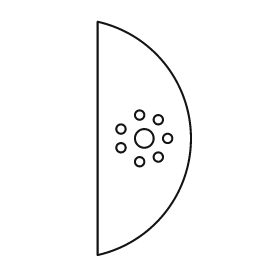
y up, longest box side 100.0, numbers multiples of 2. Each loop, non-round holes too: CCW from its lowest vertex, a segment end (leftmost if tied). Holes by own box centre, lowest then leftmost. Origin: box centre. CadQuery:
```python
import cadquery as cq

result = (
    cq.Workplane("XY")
    .moveTo(-20.0, -50.0)
    .threePointArc((20.0, 0.0), (-20.0, 50.0))
    .close()
    .moveTo(-2.0, -10.0)
    .circle(2.0)
    .moveTo(6.0, -8.0)
    .circle(2.0)
    .moveTo(-10.0, -4.0)
    .circle(2.0)
    .moveTo(0.0, 0.0)
    .circle(4.0)
    .moveTo(10.0, 0.0)
    .circle(2.0)
    .moveTo(-10.0, 4.0)
    .circle(2.0)
    .moveTo(6.0, 8.0)
    .circle(2.0)
    .moveTo(-2.0, 10.0)
    .circle(2.0)
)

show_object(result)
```